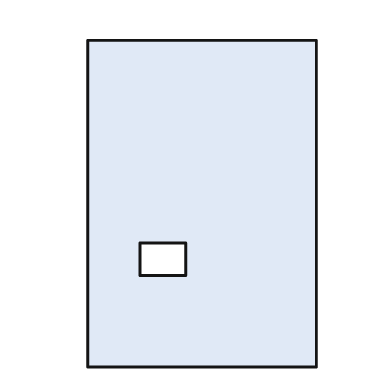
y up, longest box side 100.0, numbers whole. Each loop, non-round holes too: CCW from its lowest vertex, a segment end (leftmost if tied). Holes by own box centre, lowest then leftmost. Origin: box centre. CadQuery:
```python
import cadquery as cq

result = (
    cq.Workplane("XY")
    .moveTo(-35.0, -50.0)
    .lineTo(35.0, -50.0)
    .lineTo(35.0, 50.0)
    .lineTo(-35.0, 50.0)
    .close()
    .moveTo(-19.0, -22.0)
    .lineTo(-5.0, -22.0)
    .lineTo(-5.0, -12.0)
    .lineTo(-19.0, -12.0)
    .close()
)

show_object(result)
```